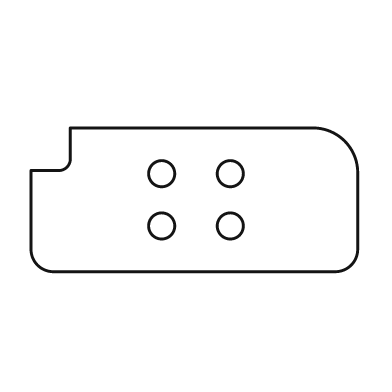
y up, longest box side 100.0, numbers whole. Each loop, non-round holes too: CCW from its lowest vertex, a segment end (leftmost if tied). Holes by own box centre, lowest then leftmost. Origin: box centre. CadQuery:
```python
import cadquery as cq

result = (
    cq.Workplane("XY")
    .moveTo(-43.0, -22.0)
    .lineTo(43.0, -22.0)
    .threePointArc((48.0, -20.0), (50.0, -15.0))
    .lineTo(50.0, 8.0)
    .threePointArc((46.0, 18.0), (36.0, 22.0))
    .lineTo(-38.0, 22.0)
    .lineTo(-38.0, 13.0)
    .threePointArc((-39.0, 10.0), (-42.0, 9.0))
    .lineTo(-50.0, 9.0)
    .lineTo(-50.0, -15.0)
    .threePointArc((-48.0, -20.0), (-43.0, -22.0))
    .close()
    .moveTo(-10.0, -8.0)
    .circle(4.0)
    .moveTo(11.0, -8.0)
    .circle(4.0)
    .moveTo(-10.0, 8.0)
    .circle(4.0)
    .moveTo(11.0, 8.0)
    .circle(4.0)
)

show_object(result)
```